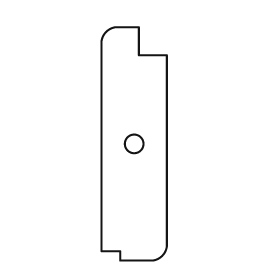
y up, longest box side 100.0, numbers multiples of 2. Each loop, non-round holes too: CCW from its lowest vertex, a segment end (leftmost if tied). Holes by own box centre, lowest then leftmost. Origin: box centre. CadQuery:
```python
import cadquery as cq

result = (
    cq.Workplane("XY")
    .moveTo(-6.0, -50.0)
    .lineTo(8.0, -50.0)
    .threePointArc((12.0, -48.0), (14.0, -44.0))
    .lineTo(14.0, 38.0)
    .lineTo(2.0, 38.0)
    .lineTo(2.0, 50.0)
    .lineTo(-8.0, 50.0)
    .threePointArc((-12.0, 48.0), (-14.0, 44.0))
    .lineTo(-14.0, -46.0)
    .lineTo(-6.0, -46.0)
    .close()
    .moveTo(0.0, 0.0)
    .circle(4.0)
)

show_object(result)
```